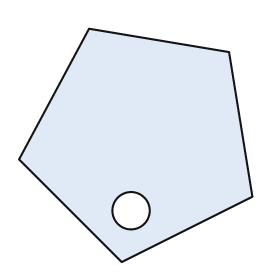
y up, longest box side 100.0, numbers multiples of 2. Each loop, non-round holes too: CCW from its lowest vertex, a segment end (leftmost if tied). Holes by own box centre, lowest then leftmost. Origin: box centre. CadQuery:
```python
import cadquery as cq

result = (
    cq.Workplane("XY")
    .moveTo(-6.0, -50.0)
    .lineTo(50.0, -22.0)
    .lineTo(40.0, 40.0)
    .lineTo(-20.0, 50.0)
    .lineTo(-50.0, -6.0)
    .close()
    .moveTo(-2.0, -28.0)
    .circle(8.0)
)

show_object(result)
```